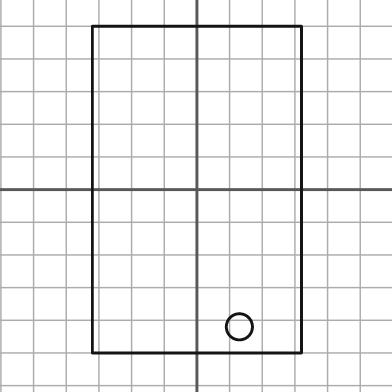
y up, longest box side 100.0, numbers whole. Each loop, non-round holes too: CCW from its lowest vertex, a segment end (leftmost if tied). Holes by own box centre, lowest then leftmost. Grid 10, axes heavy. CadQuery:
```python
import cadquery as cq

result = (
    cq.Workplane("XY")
    .moveTo(-32.0, -50.0)
    .lineTo(32.0, -50.0)
    .lineTo(32.0, 50.0)
    .lineTo(-32.0, 50.0)
    .close()
    .moveTo(13.0, -42.0)
    .circle(4.0)
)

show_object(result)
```